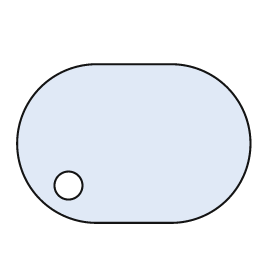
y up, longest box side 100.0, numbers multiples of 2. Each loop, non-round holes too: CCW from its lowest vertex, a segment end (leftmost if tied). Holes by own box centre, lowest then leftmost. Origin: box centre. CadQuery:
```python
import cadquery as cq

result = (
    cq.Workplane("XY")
    .moveTo(-16.0, -34.0)
    .lineTo(16.0, -34.0)
    .threePointArc((50.0, 0.0), (16.0, 34.0))
    .lineTo(-16.0, 34.0)
    .threePointArc((-50.0, 0.0), (-16.0, -34.0))
    .close()
    .moveTo(-28.0, -18.0)
    .circle(6.0)
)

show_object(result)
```